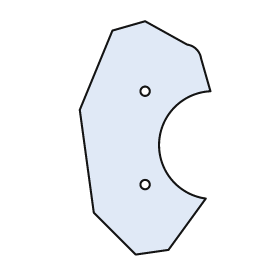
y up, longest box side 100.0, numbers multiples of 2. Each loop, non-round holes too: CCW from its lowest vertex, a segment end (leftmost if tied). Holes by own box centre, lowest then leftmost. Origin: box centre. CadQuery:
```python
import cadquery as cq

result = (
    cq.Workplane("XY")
    .moveTo(-4.0, -50.0)
    .lineTo(10.0, -48.0)
    .lineTo(26.0, -26.0)
    .threePointArc((6.0, -2.0), (28.0, 20.0))
    .lineTo(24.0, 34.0)
    .threePointArc((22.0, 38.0), (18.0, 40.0))
    .lineTo(0.0, 50.0)
    .lineTo(-14.0, 46.0)
    .lineTo(-28.0, 12.0)
    .lineTo(-22.0, -32.0)
    .close()
    .moveTo(0.0, -20.0)
    .circle(2.0)
    .moveTo(0.0, 20.0)
    .circle(2.0)
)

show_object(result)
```